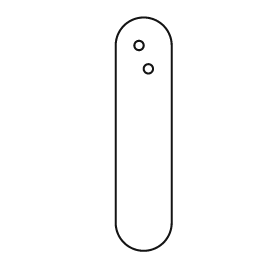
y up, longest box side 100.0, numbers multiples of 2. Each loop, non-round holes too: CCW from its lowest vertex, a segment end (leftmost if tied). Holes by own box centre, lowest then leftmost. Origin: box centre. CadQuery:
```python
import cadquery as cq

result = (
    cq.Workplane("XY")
    .moveTo(-12.0, -38.0)
    .threePointArc((0.0, -50.0), (12.0, -38.0))
    .lineTo(12.0, 38.0)
    .threePointArc((0.0, 50.0), (-12.0, 38.0))
    .close()
    .moveTo(2.0, 28.0)
    .circle(2.0)
    .moveTo(-2.0, 38.0)
    .circle(2.0)
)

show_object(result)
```